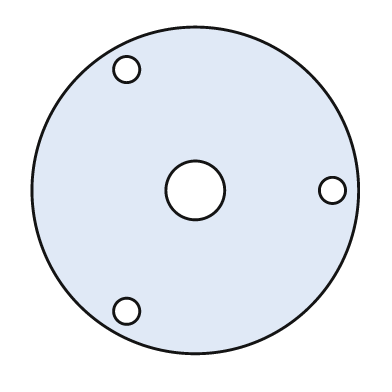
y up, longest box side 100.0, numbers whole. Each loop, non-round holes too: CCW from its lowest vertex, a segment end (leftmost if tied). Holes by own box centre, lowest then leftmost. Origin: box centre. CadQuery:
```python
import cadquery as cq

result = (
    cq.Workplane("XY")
    .moveTo(0.0, 0.0)
    .circle(50.0)
    .moveTo(-21.0, -37.0)
    .circle(4.0)
    .moveTo(0.0, 0.0)
    .circle(9.0)
    .moveTo(42.0, 0.0)
    .circle(4.0)
    .moveTo(-21.0, 37.0)
    .circle(4.0)
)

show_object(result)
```